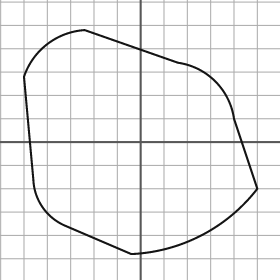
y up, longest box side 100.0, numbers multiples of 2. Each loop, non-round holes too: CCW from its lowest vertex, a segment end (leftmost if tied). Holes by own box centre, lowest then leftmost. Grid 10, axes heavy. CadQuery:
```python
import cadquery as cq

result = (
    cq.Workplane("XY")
    .moveTo(-4.0, -48.0)
    .threePointArc((26.0, -40.0), (50.0, -20.0))
    .lineTo(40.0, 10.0)
    .threePointArc((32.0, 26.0), (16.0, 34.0))
    .lineTo(-24.0, 48.0)
    .threePointArc((-40.0, 42.0), (-50.0, 28.0))
    .lineTo(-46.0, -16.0)
    .threePointArc((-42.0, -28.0), (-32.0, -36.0))
    .close()
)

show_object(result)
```